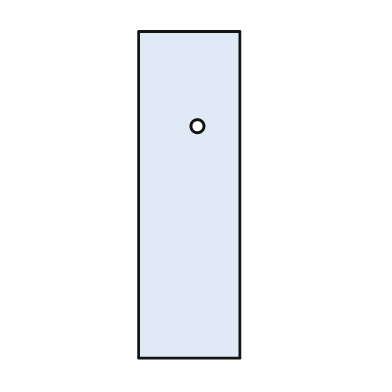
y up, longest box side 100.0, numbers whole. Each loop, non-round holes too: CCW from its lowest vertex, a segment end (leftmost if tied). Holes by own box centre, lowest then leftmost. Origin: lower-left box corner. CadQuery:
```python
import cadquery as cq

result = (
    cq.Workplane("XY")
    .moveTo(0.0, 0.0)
    .lineTo(31.0, 0.0)
    .lineTo(31.0, 100.0)
    .lineTo(0.0, 100.0)
    .close()
    .moveTo(18.0, 71.0)
    .circle(2.0)
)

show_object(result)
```